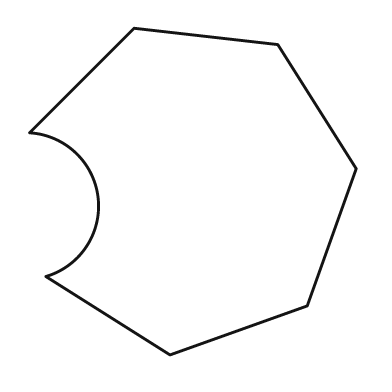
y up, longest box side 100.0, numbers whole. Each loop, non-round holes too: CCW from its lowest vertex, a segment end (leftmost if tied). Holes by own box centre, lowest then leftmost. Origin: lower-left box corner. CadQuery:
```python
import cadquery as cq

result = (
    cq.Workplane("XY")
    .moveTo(43.0, 0.0)
    .lineTo(85.0, 15.0)
    .lineTo(100.0, 57.0)
    .lineTo(76.0, 95.0)
    .lineTo(32.0, 100.0)
    .lineTo(0.0, 68.0)
    .threePointArc((21.0, 48.0), (5.0, 24.0))
    .close()
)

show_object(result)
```